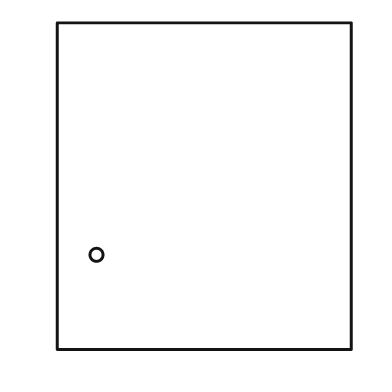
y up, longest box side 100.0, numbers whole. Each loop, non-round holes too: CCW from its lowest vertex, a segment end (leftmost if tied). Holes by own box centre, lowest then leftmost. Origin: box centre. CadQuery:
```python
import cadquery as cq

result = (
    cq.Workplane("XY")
    .moveTo(-45.0, -50.0)
    .lineTo(45.0, -50.0)
    .lineTo(45.0, 50.0)
    .lineTo(-45.0, 50.0)
    .close()
    .moveTo(-33.0, -21.0)
    .circle(2.0)
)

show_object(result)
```